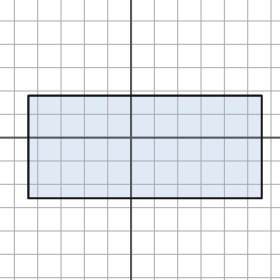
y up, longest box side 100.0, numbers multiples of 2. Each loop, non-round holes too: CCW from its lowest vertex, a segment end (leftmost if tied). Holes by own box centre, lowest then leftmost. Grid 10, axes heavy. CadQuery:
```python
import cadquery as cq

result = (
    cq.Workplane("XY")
    .moveTo(-44.0, -26.0)
    .lineTo(56.0, -26.0)
    .lineTo(56.0, 18.0)
    .lineTo(-44.0, 18.0)
    .close()
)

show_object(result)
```